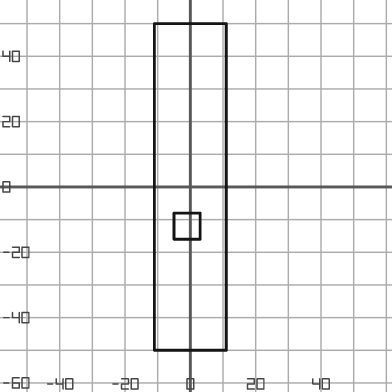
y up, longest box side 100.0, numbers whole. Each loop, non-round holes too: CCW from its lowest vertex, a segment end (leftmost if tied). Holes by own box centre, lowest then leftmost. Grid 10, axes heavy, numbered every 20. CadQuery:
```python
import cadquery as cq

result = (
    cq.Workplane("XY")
    .moveTo(-11.0, -50.0)
    .lineTo(11.0, -50.0)
    .lineTo(11.0, 50.0)
    .lineTo(-11.0, 50.0)
    .close()
    .moveTo(-5.0, -16.0)
    .lineTo(3.0, -16.0)
    .lineTo(3.0, -8.0)
    .lineTo(-5.0, -8.0)
    .close()
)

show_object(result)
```